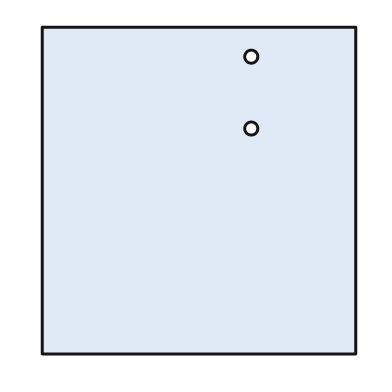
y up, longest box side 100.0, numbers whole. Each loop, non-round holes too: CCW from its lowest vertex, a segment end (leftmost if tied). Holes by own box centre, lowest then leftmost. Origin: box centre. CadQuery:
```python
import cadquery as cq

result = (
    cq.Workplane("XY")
    .moveTo(-48.0, -50.0)
    .lineTo(48.0, -50.0)
    .lineTo(48.0, 50.0)
    .lineTo(-48.0, 50.0)
    .close()
    .moveTo(16.0, 19.0)
    .circle(2.0)
    .moveTo(16.0, 41.0)
    .circle(2.0)
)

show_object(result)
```